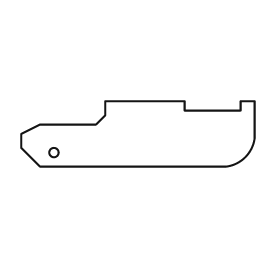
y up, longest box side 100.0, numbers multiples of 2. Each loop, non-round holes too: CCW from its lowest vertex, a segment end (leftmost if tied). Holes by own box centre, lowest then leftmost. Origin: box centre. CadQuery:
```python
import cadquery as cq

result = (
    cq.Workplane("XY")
    .moveTo(-42.0, -14.0)
    .lineTo(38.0, -14.0)
    .threePointArc((46.0, -10.0), (50.0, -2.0))
    .lineTo(50.0, 14.0)
    .lineTo(44.0, 14.0)
    .lineTo(44.0, 10.0)
    .lineTo(20.0, 10.0)
    .lineTo(20.0, 14.0)
    .lineTo(-14.0, 14.0)
    .lineTo(-14.0, 8.0)
    .lineTo(-18.0, 4.0)
    .lineTo(-42.0, 4.0)
    .lineTo(-50.0, 0.0)
    .lineTo(-50.0, -6.0)
    .close()
    .moveTo(-36.0, -8.0)
    .circle(2.0)
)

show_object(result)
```